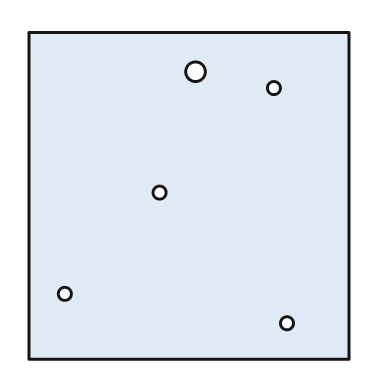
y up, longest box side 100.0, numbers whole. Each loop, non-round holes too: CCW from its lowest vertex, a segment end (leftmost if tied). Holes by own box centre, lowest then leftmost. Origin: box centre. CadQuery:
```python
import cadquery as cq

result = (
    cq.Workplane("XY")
    .moveTo(-49.0, -50.0)
    .lineTo(49.0, -50.0)
    .lineTo(49.0, 50.0)
    .lineTo(-49.0, 50.0)
    .close()
    .moveTo(30.0, -39.0)
    .circle(2.0)
    .moveTo(-38.0, -30.0)
    .circle(2.0)
    .moveTo(-9.0, 1.0)
    .circle(2.0)
    .moveTo(26.0, 33.0)
    .circle(2.0)
    .moveTo(2.0, 38.0)
    .circle(3.0)
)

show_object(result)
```